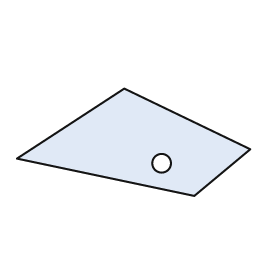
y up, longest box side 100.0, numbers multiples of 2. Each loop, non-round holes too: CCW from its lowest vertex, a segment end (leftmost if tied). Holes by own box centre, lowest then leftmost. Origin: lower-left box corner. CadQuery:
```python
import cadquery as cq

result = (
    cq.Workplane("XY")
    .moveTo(76.0, 0.0)
    .lineTo(100.0, 20.0)
    .lineTo(46.0, 46.0)
    .lineTo(0.0, 16.0)
    .close()
    .moveTo(62.0, 14.0)
    .circle(4.0)
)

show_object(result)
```